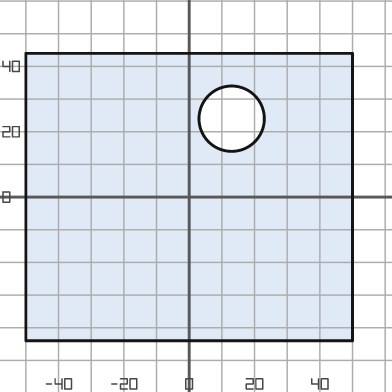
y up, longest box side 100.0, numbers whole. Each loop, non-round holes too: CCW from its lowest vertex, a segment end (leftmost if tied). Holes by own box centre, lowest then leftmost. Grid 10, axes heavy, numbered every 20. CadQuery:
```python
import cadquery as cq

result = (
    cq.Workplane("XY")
    .moveTo(-50.0, -44.0)
    .lineTo(50.0, -44.0)
    .lineTo(50.0, 44.0)
    .lineTo(-50.0, 44.0)
    .close()
    .moveTo(13.0, 24.0)
    .circle(10.0)
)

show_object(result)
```